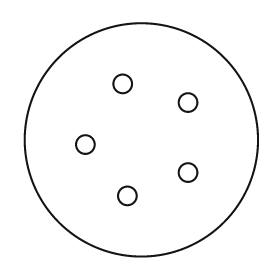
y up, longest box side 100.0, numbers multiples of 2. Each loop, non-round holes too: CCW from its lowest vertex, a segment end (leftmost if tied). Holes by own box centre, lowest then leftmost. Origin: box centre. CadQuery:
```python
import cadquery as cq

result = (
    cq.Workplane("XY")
    .moveTo(0.0, 0.0)
    .circle(50.0)
    .moveTo(-6.0, -24.0)
    .circle(4.0)
    .moveTo(20.0, -14.0)
    .circle(4.0)
    .moveTo(-24.0, -2.0)
    .circle(4.0)
    .moveTo(20.0, 16.0)
    .circle(4.0)
    .moveTo(-8.0, 24.0)
    .circle(4.0)
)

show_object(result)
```